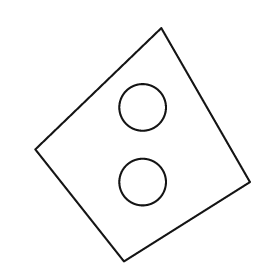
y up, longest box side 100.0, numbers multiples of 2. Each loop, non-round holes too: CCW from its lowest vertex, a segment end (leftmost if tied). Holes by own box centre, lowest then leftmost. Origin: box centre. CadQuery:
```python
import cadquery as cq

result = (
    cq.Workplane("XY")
    .moveTo(-8.0, -50.0)
    .lineTo(46.0, -16.0)
    .lineTo(8.0, 50.0)
    .lineTo(-46.0, -2.0)
    .close()
    .moveTo(0.0, -16.0)
    .circle(10.0)
    .moveTo(0.0, 16.0)
    .circle(10.0)
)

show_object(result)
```